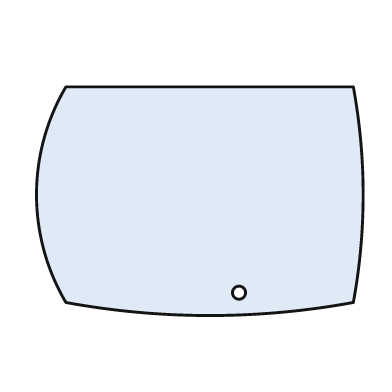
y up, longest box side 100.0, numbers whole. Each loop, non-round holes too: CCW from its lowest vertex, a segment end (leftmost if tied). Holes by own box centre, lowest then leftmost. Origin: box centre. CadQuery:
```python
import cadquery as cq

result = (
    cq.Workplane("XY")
    .moveTo(-41.0, -31.0)
    .threePointArc((3.0, -35.0), (47.0, -31.0))
    .threePointArc((50.0, 2.0), (47.0, 35.0))
    .lineTo(-41.0, 35.0)
    .threePointArc((-50.0, 2.0), (-41.0, -31.0))
    .close()
    .moveTo(12.0, -28.0)
    .circle(2.0)
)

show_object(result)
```